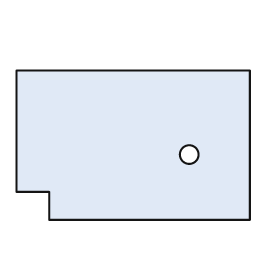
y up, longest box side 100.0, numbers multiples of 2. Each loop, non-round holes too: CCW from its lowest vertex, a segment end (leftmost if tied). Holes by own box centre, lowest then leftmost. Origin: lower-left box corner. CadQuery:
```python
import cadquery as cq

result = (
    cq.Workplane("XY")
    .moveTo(14.0, 0.0)
    .lineTo(100.0, 0.0)
    .lineTo(100.0, 64.0)
    .lineTo(0.0, 64.0)
    .lineTo(0.0, 12.0)
    .lineTo(14.0, 12.0)
    .close()
    .moveTo(74.0, 28.0)
    .circle(4.0)
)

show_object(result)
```